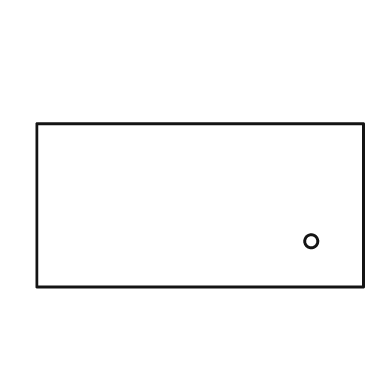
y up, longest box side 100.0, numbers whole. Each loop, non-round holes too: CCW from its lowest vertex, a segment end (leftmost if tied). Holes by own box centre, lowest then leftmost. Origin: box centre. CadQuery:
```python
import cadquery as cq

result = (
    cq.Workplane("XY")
    .moveTo(-50.0, -25.0)
    .lineTo(50.0, -25.0)
    .lineTo(50.0, 25.0)
    .lineTo(-50.0, 25.0)
    .close()
    .moveTo(34.0, -11.0)
    .circle(2.0)
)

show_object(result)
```